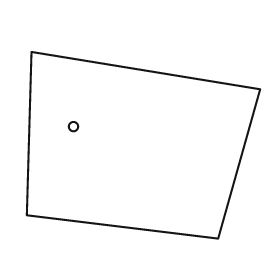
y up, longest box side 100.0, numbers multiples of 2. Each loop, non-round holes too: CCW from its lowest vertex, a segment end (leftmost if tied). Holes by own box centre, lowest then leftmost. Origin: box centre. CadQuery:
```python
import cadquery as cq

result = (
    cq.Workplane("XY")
    .moveTo(32.0, -40.0)
    .lineTo(50.0, 24.0)
    .lineTo(-48.0, 40.0)
    .lineTo(-50.0, -30.0)
    .close()
    .moveTo(-30.0, 8.0)
    .circle(2.0)
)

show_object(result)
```